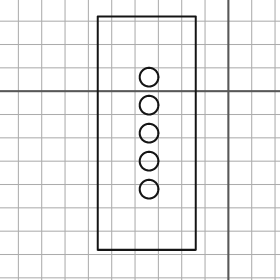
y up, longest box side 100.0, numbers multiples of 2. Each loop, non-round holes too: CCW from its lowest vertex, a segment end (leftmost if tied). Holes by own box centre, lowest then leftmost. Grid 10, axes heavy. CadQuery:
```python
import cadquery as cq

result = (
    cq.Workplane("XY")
    .moveTo(-56.0, -68.0)
    .lineTo(-14.0, -68.0)
    .lineTo(-14.0, 32.0)
    .lineTo(-56.0, 32.0)
    .close()
    .moveTo(-34.0, -42.0)
    .circle(4.0)
    .moveTo(-34.0, -30.0)
    .circle(4.0)
    .moveTo(-34.0, -18.0)
    .circle(4.0)
    .moveTo(-34.0, -6.0)
    .circle(4.0)
    .moveTo(-34.0, 6.0)
    .circle(4.0)
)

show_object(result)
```